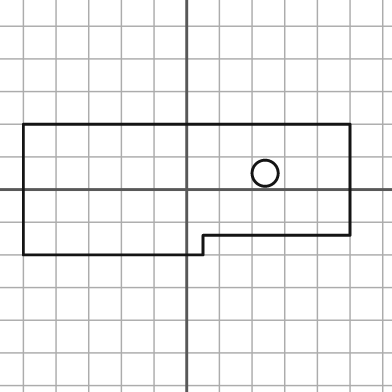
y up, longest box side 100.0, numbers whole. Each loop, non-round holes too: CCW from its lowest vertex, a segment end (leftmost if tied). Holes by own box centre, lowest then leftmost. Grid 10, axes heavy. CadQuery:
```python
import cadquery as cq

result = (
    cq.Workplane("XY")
    .moveTo(-50.0, -20.0)
    .lineTo(5.0, -20.0)
    .lineTo(5.0, -14.0)
    .lineTo(50.0, -14.0)
    .lineTo(50.0, 20.0)
    .lineTo(-50.0, 20.0)
    .close()
    .moveTo(24.0, 5.0)
    .circle(4.0)
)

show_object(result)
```